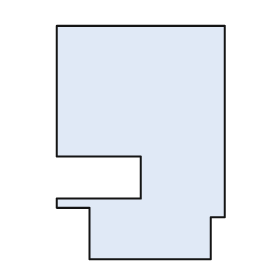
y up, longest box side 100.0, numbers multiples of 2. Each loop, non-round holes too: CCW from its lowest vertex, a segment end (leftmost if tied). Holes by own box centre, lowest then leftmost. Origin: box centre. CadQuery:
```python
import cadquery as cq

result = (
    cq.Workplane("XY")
    .moveTo(-22.0, -50.0)
    .lineTo(30.0, -50.0)
    .lineTo(30.0, -32.0)
    .lineTo(36.0, -32.0)
    .lineTo(36.0, 50.0)
    .lineTo(-36.0, 50.0)
    .lineTo(-36.0, -6.0)
    .lineTo(0.0, -6.0)
    .lineTo(0.0, -24.0)
    .lineTo(-36.0, -24.0)
    .lineTo(-36.0, -28.0)
    .lineTo(-22.0, -28.0)
    .close()
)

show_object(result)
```